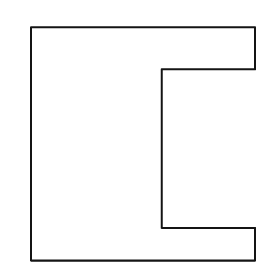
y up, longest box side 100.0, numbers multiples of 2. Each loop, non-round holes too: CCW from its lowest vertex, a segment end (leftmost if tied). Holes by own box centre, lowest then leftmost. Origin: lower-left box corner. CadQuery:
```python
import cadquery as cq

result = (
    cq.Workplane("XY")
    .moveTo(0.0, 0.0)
    .lineTo(96.0, 0.0)
    .lineTo(96.0, 14.0)
    .lineTo(56.0, 14.0)
    .lineTo(56.0, 82.0)
    .lineTo(96.0, 82.0)
    .lineTo(96.0, 100.0)
    .lineTo(0.0, 100.0)
    .close()
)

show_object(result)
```